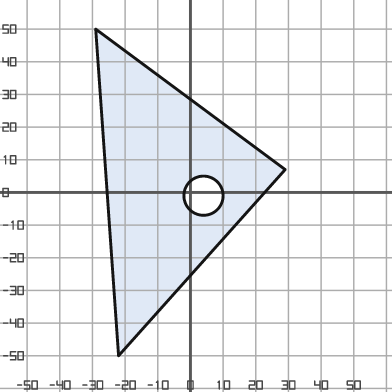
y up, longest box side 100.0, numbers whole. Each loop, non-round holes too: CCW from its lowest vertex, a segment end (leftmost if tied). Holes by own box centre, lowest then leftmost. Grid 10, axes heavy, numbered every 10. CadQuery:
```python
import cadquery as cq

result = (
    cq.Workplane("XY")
    .moveTo(-22.0, -50.0)
    .lineTo(29.0, 7.0)
    .lineTo(-29.0, 50.0)
    .close()
    .moveTo(4.0, -1.0)
    .circle(6.0)
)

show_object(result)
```